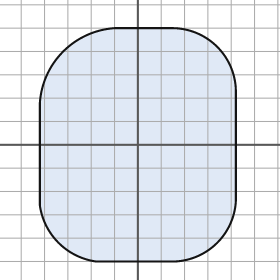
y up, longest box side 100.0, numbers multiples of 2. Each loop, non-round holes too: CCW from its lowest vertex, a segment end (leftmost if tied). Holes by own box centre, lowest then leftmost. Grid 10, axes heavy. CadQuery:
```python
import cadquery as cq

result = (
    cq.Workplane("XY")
    .moveTo(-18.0, -50.0)
    .lineTo(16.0, -50.0)
    .threePointArc((34.0, -42.0), (42.0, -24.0))
    .lineTo(42.0, 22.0)
    .threePointArc((34.0, 42.0), (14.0, 50.0))
    .lineTo(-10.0, 50.0)
    .threePointArc((-32.0, 40.0), (-42.0, 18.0))
    .lineTo(-42.0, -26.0)
    .threePointArc((-34.0, -42.0), (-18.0, -50.0))
    .close()
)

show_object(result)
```